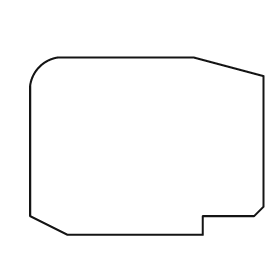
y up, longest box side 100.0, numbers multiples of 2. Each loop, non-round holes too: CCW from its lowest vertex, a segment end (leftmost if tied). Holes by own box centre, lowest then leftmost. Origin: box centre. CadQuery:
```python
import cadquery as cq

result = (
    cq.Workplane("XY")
    .moveTo(-34.0, -38.0)
    .lineTo(24.0, -38.0)
    .lineTo(24.0, -30.0)
    .lineTo(46.0, -30.0)
    .lineTo(50.0, -26.0)
    .lineTo(50.0, 30.0)
    .lineTo(20.0, 38.0)
    .lineTo(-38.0, 38.0)
    .threePointArc((-46.0, 34.0), (-50.0, 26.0))
    .lineTo(-50.0, -30.0)
    .close()
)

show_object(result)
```